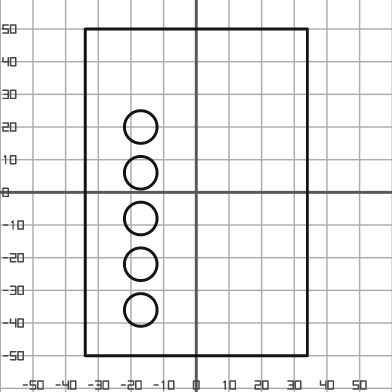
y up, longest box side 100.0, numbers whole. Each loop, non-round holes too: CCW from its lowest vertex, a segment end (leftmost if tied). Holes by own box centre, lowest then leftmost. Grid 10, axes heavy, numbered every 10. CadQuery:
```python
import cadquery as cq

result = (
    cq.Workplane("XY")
    .moveTo(-34.0, -50.0)
    .lineTo(34.0, -50.0)
    .lineTo(34.0, 50.0)
    .lineTo(-34.0, 50.0)
    .close()
    .moveTo(-17.0, -36.0)
    .circle(5.0)
    .moveTo(-17.0, -22.0)
    .circle(5.0)
    .moveTo(-17.0, -8.0)
    .circle(5.0)
    .moveTo(-17.0, 6.0)
    .circle(5.0)
    .moveTo(-17.0, 20.0)
    .circle(5.0)
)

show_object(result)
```